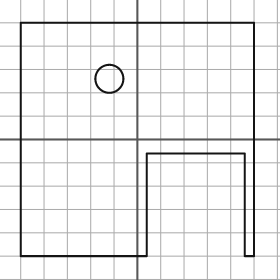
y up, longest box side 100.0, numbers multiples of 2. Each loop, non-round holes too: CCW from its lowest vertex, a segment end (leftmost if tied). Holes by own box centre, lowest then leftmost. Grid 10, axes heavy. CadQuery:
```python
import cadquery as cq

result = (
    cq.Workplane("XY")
    .moveTo(-50.0, -50.0)
    .lineTo(4.0, -50.0)
    .lineTo(4.0, -6.0)
    .lineTo(46.0, -6.0)
    .lineTo(46.0, -50.0)
    .lineTo(50.0, -50.0)
    .lineTo(50.0, 50.0)
    .lineTo(-50.0, 50.0)
    .close()
    .moveTo(-12.0, 26.0)
    .circle(6.0)
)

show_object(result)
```